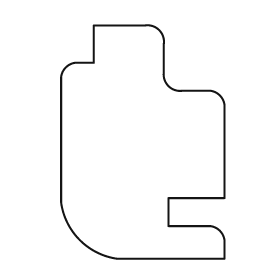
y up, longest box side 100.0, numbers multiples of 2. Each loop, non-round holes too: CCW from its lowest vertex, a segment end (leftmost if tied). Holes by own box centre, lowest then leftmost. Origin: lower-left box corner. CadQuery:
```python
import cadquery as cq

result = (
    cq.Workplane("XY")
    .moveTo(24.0, 0.0)
    .lineTo(70.0, 0.0)
    .lineTo(70.0, 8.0)
    .threePointArc((68.0, 12.0), (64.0, 14.0))
    .lineTo(46.0, 14.0)
    .lineTo(46.0, 26.0)
    .lineTo(70.0, 26.0)
    .lineTo(70.0, 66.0)
    .threePointArc((68.0, 70.0), (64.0, 72.0))
    .lineTo(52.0, 72.0)
    .threePointArc((46.0, 74.0), (44.0, 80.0))
    .lineTo(44.0, 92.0)
    .threePointArc((42.0, 98.0), (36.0, 100.0))
    .lineTo(14.0, 100.0)
    .lineTo(14.0, 84.0)
    .lineTo(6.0, 84.0)
    .threePointArc((2.0, 82.0), (0.0, 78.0))
    .lineTo(0.0, 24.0)
    .threePointArc((8.0, 8.0), (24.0, 0.0))
    .close()
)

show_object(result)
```